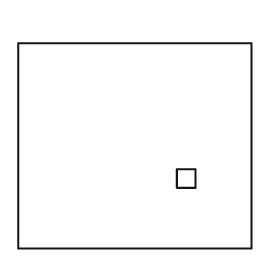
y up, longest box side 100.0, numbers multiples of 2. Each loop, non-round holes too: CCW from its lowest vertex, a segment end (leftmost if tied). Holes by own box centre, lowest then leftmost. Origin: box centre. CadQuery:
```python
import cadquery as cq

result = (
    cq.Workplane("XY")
    .moveTo(-50.0, -44.0)
    .lineTo(50.0, -44.0)
    .lineTo(50.0, 44.0)
    .lineTo(-50.0, 44.0)
    .close()
    .moveTo(18.0, -18.0)
    .lineTo(26.0, -18.0)
    .lineTo(26.0, -10.0)
    .lineTo(18.0, -10.0)
    .close()
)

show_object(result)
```